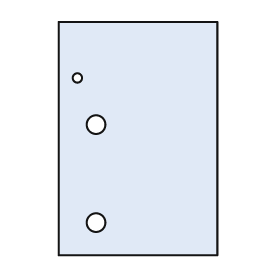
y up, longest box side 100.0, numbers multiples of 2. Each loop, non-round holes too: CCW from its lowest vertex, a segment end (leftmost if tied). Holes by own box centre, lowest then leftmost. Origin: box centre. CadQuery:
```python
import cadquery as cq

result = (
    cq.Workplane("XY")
    .moveTo(-34.0, -50.0)
    .lineTo(34.0, -50.0)
    .lineTo(34.0, 50.0)
    .lineTo(-34.0, 50.0)
    .close()
    .moveTo(-18.0, -36.0)
    .circle(4.0)
    .moveTo(-18.0, 6.0)
    .circle(4.0)
    .moveTo(-26.0, 26.0)
    .circle(2.0)
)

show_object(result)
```